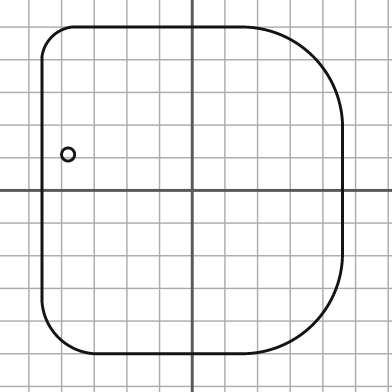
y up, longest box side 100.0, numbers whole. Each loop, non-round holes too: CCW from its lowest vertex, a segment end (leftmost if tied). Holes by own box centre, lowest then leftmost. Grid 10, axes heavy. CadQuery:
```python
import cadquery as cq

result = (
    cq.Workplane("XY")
    .moveTo(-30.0, -50.0)
    .lineTo(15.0, -50.0)
    .threePointArc((37.0, -41.0), (46.0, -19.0))
    .lineTo(46.0, 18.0)
    .threePointArc((37.0, 41.0), (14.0, 50.0))
    .lineTo(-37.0, 50.0)
    .threePointArc((-43.0, 47.0), (-46.0, 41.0))
    .lineTo(-46.0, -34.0)
    .threePointArc((-41.0, -45.0), (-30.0, -50.0))
    .close()
    .moveTo(-38.0, 11.0)
    .circle(2.0)
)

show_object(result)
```